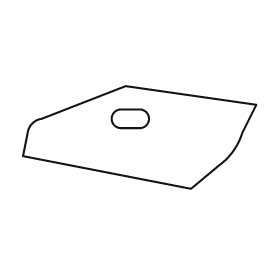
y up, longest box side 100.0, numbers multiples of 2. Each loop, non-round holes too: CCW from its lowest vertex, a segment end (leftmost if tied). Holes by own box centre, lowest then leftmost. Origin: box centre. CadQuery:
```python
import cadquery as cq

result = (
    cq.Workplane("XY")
    .moveTo(22.0, -22.0)
    .lineTo(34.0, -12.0)
    .threePointArc((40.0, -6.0), (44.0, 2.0))
    .lineTo(50.0, 14.0)
    .lineTo(-6.0, 22.0)
    .lineTo(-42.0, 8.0)
    .threePointArc((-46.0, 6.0), (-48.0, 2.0))
    .lineTo(-50.0, -8.0)
    .close()
    .moveTo(-8.0, 4.0)
    .lineTo(0.0, 4.0)
    .threePointArc((4.0, 8.0), (0.0, 12.0))
    .lineTo(-8.0, 12.0)
    .threePointArc((-12.0, 8.0), (-8.0, 4.0))
    .close()
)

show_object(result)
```